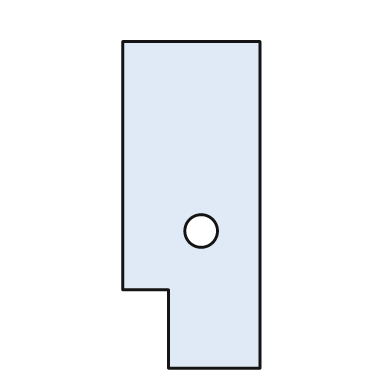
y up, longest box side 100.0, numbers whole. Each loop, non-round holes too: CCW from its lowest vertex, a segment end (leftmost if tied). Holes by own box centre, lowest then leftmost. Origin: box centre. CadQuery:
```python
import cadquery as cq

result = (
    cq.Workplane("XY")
    .moveTo(-7.0, -50.0)
    .lineTo(21.0, -50.0)
    .lineTo(21.0, 50.0)
    .lineTo(-21.0, 50.0)
    .lineTo(-21.0, -26.0)
    .lineTo(-7.0, -26.0)
    .close()
    .moveTo(3.0, -8.0)
    .circle(5.0)
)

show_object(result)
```